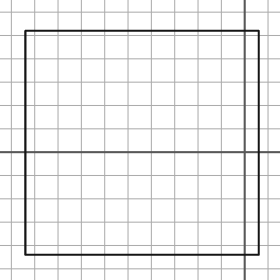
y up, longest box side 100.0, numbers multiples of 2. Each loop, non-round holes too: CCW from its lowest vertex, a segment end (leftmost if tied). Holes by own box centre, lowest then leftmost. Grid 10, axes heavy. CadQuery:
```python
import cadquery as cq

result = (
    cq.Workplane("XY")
    .moveTo(-94.0, -44.0)
    .lineTo(6.0, -44.0)
    .lineTo(6.0, 52.0)
    .lineTo(-94.0, 52.0)
    .close()
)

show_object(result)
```